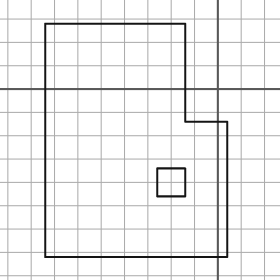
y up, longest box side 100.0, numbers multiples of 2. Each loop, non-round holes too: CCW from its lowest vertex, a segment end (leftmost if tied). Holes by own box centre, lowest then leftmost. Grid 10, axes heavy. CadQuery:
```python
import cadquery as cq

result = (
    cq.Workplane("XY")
    .moveTo(-74.0, -72.0)
    .lineTo(4.0, -72.0)
    .lineTo(4.0, -14.0)
    .lineTo(-14.0, -14.0)
    .lineTo(-14.0, 28.0)
    .lineTo(-74.0, 28.0)
    .close()
    .moveTo(-26.0, -46.0)
    .lineTo(-14.0, -46.0)
    .lineTo(-14.0, -34.0)
    .lineTo(-26.0, -34.0)
    .close()
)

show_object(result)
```